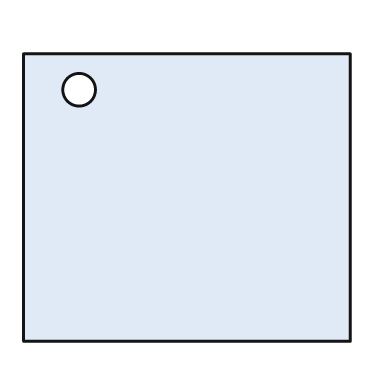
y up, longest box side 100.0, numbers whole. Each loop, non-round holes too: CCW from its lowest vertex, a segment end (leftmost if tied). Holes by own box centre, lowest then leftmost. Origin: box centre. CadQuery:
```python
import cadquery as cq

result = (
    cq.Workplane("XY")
    .moveTo(-50.0, -44.0)
    .lineTo(50.0, -44.0)
    .lineTo(50.0, 44.0)
    .lineTo(-50.0, 44.0)
    .close()
    .moveTo(-33.0, 33.0)
    .circle(5.0)
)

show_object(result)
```